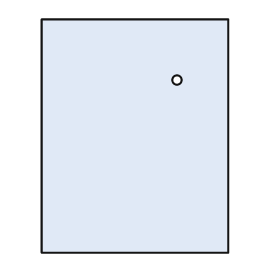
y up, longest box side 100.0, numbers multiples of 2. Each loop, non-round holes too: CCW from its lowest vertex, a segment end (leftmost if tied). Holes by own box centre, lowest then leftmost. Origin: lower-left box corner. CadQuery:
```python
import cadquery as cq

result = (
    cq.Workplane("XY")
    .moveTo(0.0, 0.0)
    .lineTo(80.0, 0.0)
    .lineTo(80.0, 100.0)
    .lineTo(0.0, 100.0)
    .close()
    .moveTo(58.0, 74.0)
    .circle(2.0)
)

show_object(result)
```